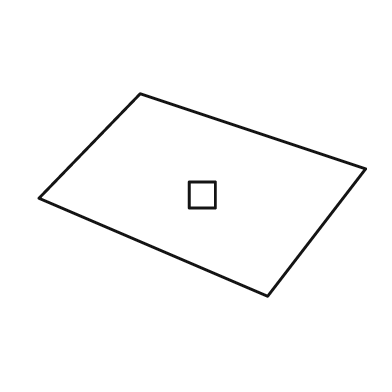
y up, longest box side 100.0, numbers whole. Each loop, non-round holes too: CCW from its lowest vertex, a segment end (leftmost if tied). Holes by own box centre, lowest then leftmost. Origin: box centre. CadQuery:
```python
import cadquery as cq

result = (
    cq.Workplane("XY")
    .moveTo(20.0, -31.0)
    .lineTo(50.0, 8.0)
    .lineTo(-19.0, 31.0)
    .lineTo(-50.0, -1.0)
    .close()
    .moveTo(-4.0, -4.0)
    .lineTo(4.0, -4.0)
    .lineTo(4.0, 4.0)
    .lineTo(-4.0, 4.0)
    .close()
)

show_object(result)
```